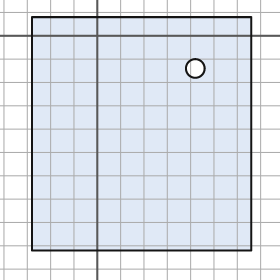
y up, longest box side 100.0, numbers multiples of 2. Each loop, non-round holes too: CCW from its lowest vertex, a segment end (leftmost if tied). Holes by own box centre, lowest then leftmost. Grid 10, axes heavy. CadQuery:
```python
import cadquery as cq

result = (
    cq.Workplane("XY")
    .moveTo(-28.0, -92.0)
    .lineTo(66.0, -92.0)
    .lineTo(66.0, 8.0)
    .lineTo(-28.0, 8.0)
    .close()
    .moveTo(42.0, -14.0)
    .circle(4.0)
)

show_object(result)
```